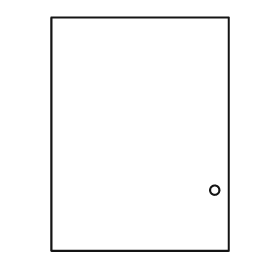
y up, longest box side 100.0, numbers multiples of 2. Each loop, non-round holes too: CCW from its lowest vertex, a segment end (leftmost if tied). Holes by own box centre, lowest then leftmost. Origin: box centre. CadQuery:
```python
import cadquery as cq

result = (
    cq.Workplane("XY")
    .moveTo(-38.0, -50.0)
    .lineTo(38.0, -50.0)
    .lineTo(38.0, 50.0)
    .lineTo(-38.0, 50.0)
    .close()
    .moveTo(32.0, -24.0)
    .circle(2.0)
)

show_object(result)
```